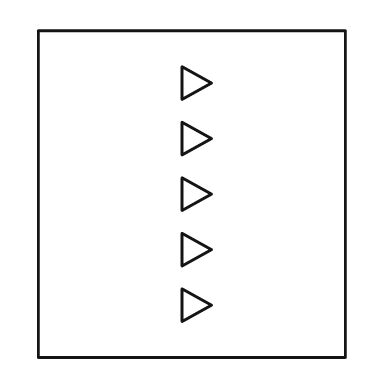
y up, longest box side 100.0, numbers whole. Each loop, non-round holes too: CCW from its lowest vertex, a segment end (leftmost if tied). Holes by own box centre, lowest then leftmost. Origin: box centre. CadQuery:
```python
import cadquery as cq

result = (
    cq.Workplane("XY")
    .moveTo(-47.0, -50.0)
    .lineTo(47.0, -50.0)
    .lineTo(47.0, 50.0)
    .lineTo(-47.0, 50.0)
    .close()
    .moveTo(-3.0, -39.0)
    .lineTo(6.0, -34.0)
    .lineTo(-3.0, -29.0)
    .close()
    .moveTo(-3.0, -22.0)
    .lineTo(6.0, -17.0)
    .lineTo(-3.0, -12.0)
    .close()
    .moveTo(-3.0, -5.0)
    .lineTo(6.0, 0.0)
    .lineTo(-3.0, 5.0)
    .close()
    .moveTo(-3.0, 12.0)
    .lineTo(6.0, 17.0)
    .lineTo(-3.0, 22.0)
    .close()
    .moveTo(-3.0, 29.0)
    .lineTo(6.0, 34.0)
    .lineTo(-3.0, 39.0)
    .close()
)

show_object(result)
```